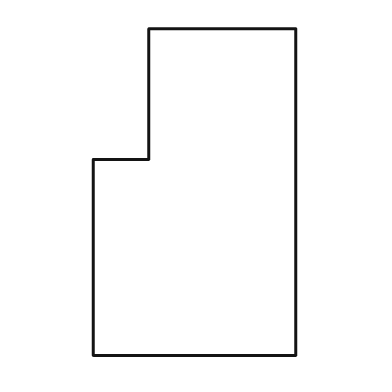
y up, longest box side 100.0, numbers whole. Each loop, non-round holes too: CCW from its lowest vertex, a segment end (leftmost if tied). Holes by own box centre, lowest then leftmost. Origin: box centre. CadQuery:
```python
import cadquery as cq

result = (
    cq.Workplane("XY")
    .moveTo(-31.0, -50.0)
    .lineTo(31.0, -50.0)
    .lineTo(31.0, 50.0)
    .lineTo(-14.0, 50.0)
    .lineTo(-14.0, 10.0)
    .lineTo(-31.0, 10.0)
    .close()
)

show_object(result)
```